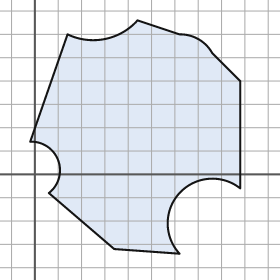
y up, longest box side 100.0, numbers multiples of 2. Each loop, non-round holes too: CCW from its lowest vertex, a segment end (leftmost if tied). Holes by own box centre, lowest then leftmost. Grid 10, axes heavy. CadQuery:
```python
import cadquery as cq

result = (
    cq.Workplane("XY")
    .moveTo(62.0, -34.0)
    .threePointArc((62.0, -8.0), (88.0, -6.0))
    .lineTo(88.0, 40.0)
    .lineTo(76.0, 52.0)
    .threePointArc((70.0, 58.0), (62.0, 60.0))
    .lineTo(44.0, 66.0)
    .threePointArc((30.0, 58.0), (14.0, 60.0))
    .lineTo(-2.0, 14.0)
    .threePointArc((10.0, 6.0), (6.0, -8.0))
    .lineTo(34.0, -32.0)
    .close()
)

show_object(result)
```